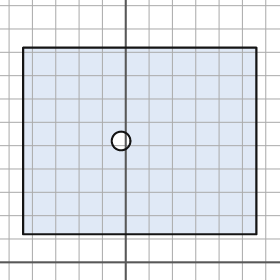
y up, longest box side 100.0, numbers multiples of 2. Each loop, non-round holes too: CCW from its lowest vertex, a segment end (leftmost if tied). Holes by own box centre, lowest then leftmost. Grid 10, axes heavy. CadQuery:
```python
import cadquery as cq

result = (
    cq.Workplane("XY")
    .moveTo(-44.0, 12.0)
    .lineTo(56.0, 12.0)
    .lineTo(56.0, 92.0)
    .lineTo(-44.0, 92.0)
    .close()
    .moveTo(-2.0, 52.0)
    .circle(4.0)
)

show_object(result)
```